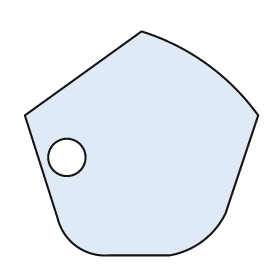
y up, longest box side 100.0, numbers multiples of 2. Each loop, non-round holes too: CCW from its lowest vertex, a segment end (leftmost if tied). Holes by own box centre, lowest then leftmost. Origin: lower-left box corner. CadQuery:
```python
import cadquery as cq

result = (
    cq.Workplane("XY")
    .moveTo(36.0, 0.0)
    .lineTo(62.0, 0.0)
    .threePointArc((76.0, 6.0), (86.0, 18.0))
    .lineTo(100.0, 60.0)
    .threePointArc((78.0, 82.0), (50.0, 96.0))
    .lineTo(0.0, 60.0)
    .lineTo(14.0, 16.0)
    .threePointArc((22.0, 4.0), (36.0, 0.0))
    .close()
    .moveTo(18.0, 42.0)
    .circle(8.0)
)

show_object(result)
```